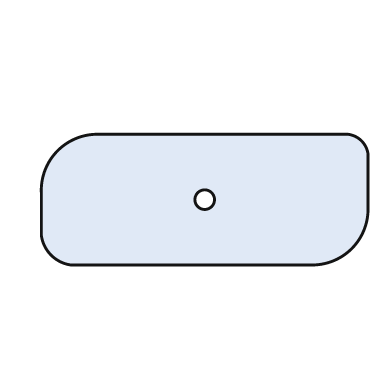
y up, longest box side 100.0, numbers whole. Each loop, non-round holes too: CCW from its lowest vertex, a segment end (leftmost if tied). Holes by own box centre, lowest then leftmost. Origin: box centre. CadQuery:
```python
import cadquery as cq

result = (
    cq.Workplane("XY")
    .moveTo(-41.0, -20.0)
    .lineTo(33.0, -20.0)
    .threePointArc((45.0, -15.0), (50.0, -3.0))
    .lineTo(50.0, 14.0)
    .threePointArc((48.0, 18.0), (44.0, 20.0))
    .lineTo(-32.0, 20.0)
    .threePointArc((-45.0, 15.0), (-50.0, 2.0))
    .lineTo(-50.0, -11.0)
    .threePointArc((-47.0, -17.0), (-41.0, -20.0))
    .close()
    .moveTo(0.0, 0.0)
    .circle(3.0)
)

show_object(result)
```